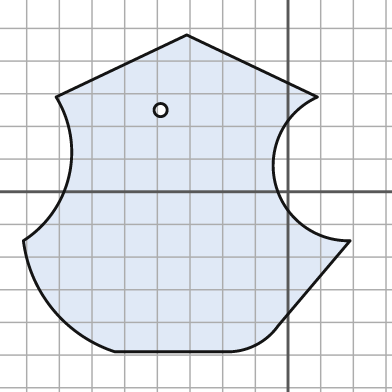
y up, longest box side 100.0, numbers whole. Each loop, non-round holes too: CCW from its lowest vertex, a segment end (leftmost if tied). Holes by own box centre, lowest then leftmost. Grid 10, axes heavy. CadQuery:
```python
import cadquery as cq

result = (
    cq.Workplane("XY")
    .moveTo(-53.0, -49.0)
    .lineTo(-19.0, -49.0)
    .threePointArc((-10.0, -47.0), (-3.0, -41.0))
    .lineTo(19.0, -15.0)
    .threePointArc((-4.0, 3.0), (9.0, 29.0))
    .lineTo(-31.0, 48.0)
    .lineTo(-71.0, 29.0)
    .threePointArc((-67.0, 5.0), (-81.0, -15.0))
    .threePointArc((-72.0, -36.0), (-53.0, -49.0))
    .close()
    .moveTo(-39.0, 25.0)
    .circle(2.0)
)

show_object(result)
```